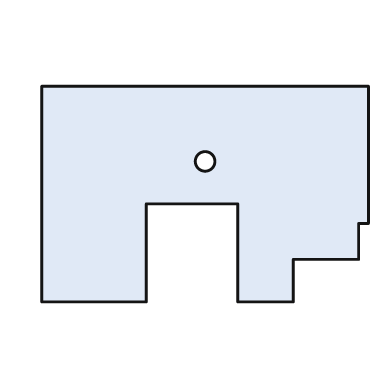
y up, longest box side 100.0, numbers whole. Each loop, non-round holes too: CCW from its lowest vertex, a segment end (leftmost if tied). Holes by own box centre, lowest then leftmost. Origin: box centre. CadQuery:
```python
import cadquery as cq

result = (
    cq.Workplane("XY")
    .moveTo(-50.0, -33.0)
    .lineTo(-18.0, -33.0)
    .lineTo(-18.0, -3.0)
    .lineTo(10.0, -3.0)
    .lineTo(10.0, -33.0)
    .lineTo(27.0, -33.0)
    .lineTo(27.0, -20.0)
    .lineTo(47.0, -20.0)
    .lineTo(47.0, -9.0)
    .lineTo(50.0, -9.0)
    .lineTo(50.0, 33.0)
    .lineTo(-50.0, 33.0)
    .close()
    .moveTo(0.0, 10.0)
    .circle(3.0)
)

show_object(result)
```